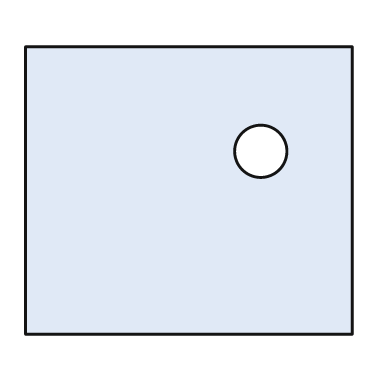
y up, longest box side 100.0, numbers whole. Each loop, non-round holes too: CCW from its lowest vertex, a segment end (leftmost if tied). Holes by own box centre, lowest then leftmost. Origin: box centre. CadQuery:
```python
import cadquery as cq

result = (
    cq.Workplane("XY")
    .moveTo(-50.0, -44.0)
    .lineTo(50.0, -44.0)
    .lineTo(50.0, 44.0)
    .lineTo(-50.0, 44.0)
    .close()
    .moveTo(22.0, 12.0)
    .circle(8.0)
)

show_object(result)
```